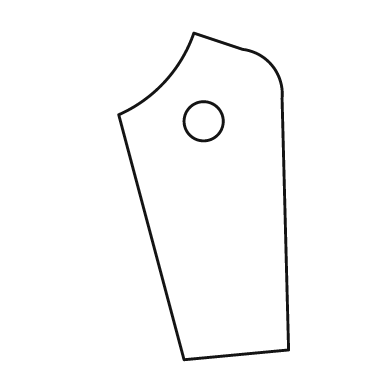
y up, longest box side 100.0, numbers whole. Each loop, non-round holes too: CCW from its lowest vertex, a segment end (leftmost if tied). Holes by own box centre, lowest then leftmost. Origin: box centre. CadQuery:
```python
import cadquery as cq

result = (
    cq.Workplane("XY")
    .moveTo(-6.0, -50.0)
    .lineTo(26.0, -47.0)
    .lineTo(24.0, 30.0)
    .threePointArc((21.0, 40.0), (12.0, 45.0))
    .lineTo(-3.0, 50.0)
    .threePointArc((-12.0, 35.0), (-26.0, 25.0))
    .close()
    .moveTo(0.0, 23.0)
    .circle(6.0)
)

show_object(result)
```